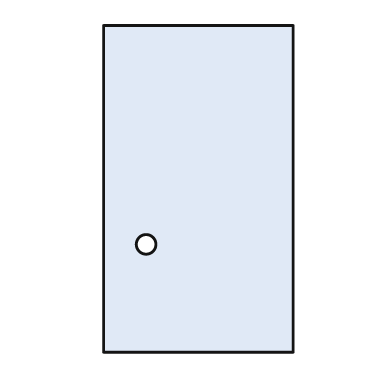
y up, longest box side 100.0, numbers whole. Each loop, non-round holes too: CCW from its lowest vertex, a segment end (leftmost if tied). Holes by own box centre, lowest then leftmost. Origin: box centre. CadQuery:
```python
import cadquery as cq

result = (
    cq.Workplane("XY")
    .moveTo(-29.0, -50.0)
    .lineTo(29.0, -50.0)
    .lineTo(29.0, 50.0)
    .lineTo(-29.0, 50.0)
    .close()
    .moveTo(-16.0, -17.0)
    .circle(3.0)
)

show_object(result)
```